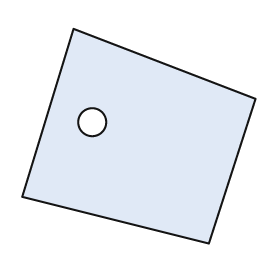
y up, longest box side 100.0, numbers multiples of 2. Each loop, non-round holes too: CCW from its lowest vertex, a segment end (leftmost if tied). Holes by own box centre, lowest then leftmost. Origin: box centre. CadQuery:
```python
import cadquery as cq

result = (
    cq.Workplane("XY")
    .moveTo(30.0, -46.0)
    .lineTo(50.0, 16.0)
    .lineTo(-28.0, 46.0)
    .lineTo(-50.0, -26.0)
    .close()
    .moveTo(-20.0, 6.0)
    .circle(6.0)
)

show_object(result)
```